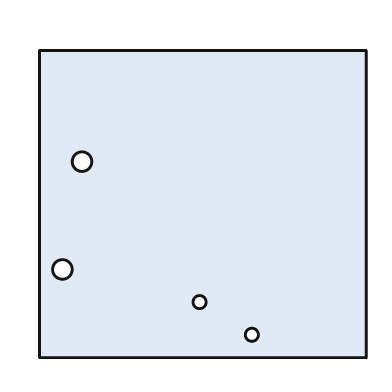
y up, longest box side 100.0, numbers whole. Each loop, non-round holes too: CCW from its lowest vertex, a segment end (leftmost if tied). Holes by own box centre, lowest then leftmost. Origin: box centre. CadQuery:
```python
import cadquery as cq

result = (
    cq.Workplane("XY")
    .moveTo(-50.0, -47.0)
    .lineTo(50.0, -47.0)
    .lineTo(50.0, 47.0)
    .lineTo(-50.0, 47.0)
    .close()
    .moveTo(15.0, -40.0)
    .circle(2.0)
    .moveTo(-1.0, -30.0)
    .circle(2.0)
    .moveTo(-43.0, -20.0)
    .circle(3.0)
    .moveTo(-37.0, 13.0)
    .circle(3.0)
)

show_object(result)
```